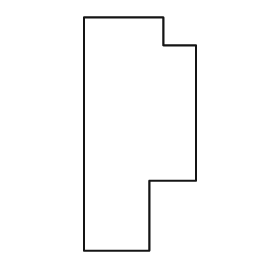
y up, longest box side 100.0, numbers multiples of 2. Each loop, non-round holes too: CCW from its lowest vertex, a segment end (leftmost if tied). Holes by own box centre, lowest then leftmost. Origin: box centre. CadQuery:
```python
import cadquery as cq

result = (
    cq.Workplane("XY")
    .moveTo(-24.0, -50.0)
    .lineTo(4.0, -50.0)
    .lineTo(4.0, -20.0)
    .lineTo(24.0, -20.0)
    .lineTo(24.0, 38.0)
    .lineTo(10.0, 38.0)
    .lineTo(10.0, 50.0)
    .lineTo(-24.0, 50.0)
    .close()
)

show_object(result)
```